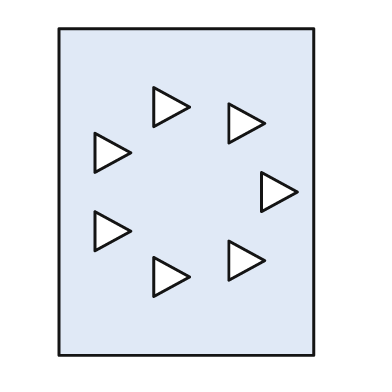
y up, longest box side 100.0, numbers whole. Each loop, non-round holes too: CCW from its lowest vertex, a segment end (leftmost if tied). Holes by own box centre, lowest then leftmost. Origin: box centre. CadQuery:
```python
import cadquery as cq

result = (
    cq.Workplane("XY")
    .moveTo(-39.0, -50.0)
    .lineTo(39.0, -50.0)
    .lineTo(39.0, 50.0)
    .lineTo(-39.0, 50.0)
    .close()
    .moveTo(-10.0, -32.0)
    .lineTo(1.0, -26.0)
    .lineTo(-10.0, -20.0)
    .close()
    .moveTo(13.0, -27.0)
    .lineTo(24.0, -21.0)
    .lineTo(13.0, -15.0)
    .close()
    .moveTo(-28.0, -18.0)
    .lineTo(-17.0, -12.0)
    .lineTo(-28.0, -6.0)
    .close()
    .moveTo(23.0, -6.0)
    .lineTo(34.0, 0.0)
    .lineTo(23.0, 6.0)
    .close()
    .moveTo(-28.0, 6.0)
    .lineTo(-17.0, 12.0)
    .lineTo(-28.0, 18.0)
    .close()
    .moveTo(13.0, 15.0)
    .lineTo(24.0, 21.0)
    .lineTo(13.0, 27.0)
    .close()
    .moveTo(-10.0, 20.0)
    .lineTo(1.0, 26.0)
    .lineTo(-10.0, 32.0)
    .close()
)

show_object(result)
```